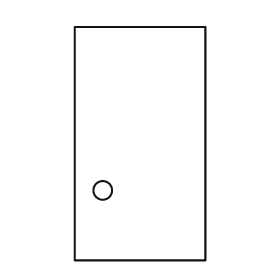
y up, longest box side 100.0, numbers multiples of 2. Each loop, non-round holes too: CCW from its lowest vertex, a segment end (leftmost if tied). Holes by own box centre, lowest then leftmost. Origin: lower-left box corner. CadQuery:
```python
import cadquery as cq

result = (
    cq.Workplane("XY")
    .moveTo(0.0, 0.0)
    .lineTo(56.0, 0.0)
    .lineTo(56.0, 100.0)
    .lineTo(0.0, 100.0)
    .close()
    .moveTo(12.0, 30.0)
    .circle(4.0)
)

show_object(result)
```